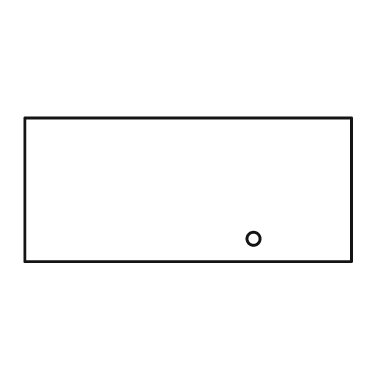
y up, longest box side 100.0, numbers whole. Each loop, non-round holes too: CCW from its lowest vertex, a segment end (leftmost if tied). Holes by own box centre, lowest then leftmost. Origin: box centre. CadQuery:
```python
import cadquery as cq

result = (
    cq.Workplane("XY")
    .moveTo(-50.0, -22.0)
    .lineTo(50.0, -22.0)
    .lineTo(50.0, 22.0)
    .lineTo(-50.0, 22.0)
    .close()
    .moveTo(20.0, -15.0)
    .circle(2.0)
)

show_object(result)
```